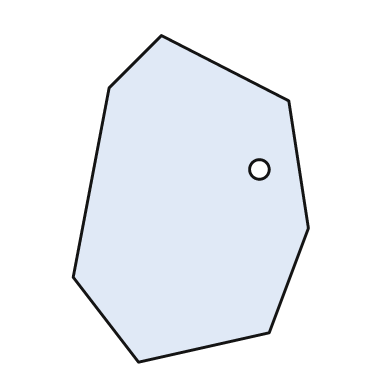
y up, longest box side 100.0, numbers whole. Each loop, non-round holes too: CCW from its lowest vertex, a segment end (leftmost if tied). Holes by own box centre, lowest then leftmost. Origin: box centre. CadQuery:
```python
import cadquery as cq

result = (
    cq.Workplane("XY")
    .moveTo(-16.0, -50.0)
    .lineTo(24.0, -41.0)
    .lineTo(36.0, -9.0)
    .lineTo(30.0, 30.0)
    .lineTo(-9.0, 50.0)
    .lineTo(-25.0, 34.0)
    .lineTo(-36.0, -24.0)
    .close()
    .moveTo(21.0, 9.0)
    .circle(3.0)
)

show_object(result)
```